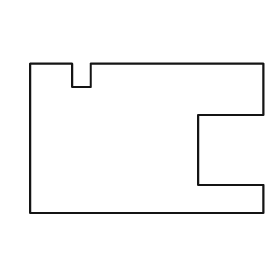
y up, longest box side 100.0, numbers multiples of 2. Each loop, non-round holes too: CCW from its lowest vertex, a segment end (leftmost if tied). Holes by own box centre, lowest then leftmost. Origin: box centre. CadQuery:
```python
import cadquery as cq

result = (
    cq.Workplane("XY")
    .moveTo(-50.0, -32.0)
    .lineTo(50.0, -32.0)
    .lineTo(50.0, -20.0)
    .lineTo(22.0, -20.0)
    .lineTo(22.0, 10.0)
    .lineTo(50.0, 10.0)
    .lineTo(50.0, 32.0)
    .lineTo(-24.0, 32.0)
    .lineTo(-24.0, 22.0)
    .lineTo(-32.0, 22.0)
    .lineTo(-32.0, 32.0)
    .lineTo(-50.0, 32.0)
    .close()
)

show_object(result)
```